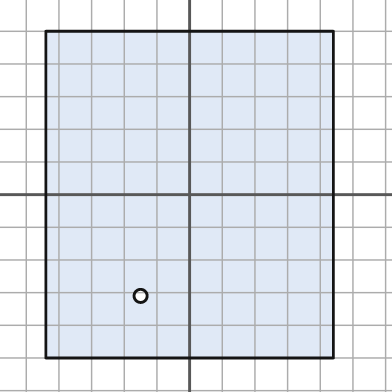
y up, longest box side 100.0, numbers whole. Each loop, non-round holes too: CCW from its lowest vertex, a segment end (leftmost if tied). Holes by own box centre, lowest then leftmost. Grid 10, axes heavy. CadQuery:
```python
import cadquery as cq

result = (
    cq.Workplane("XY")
    .moveTo(-44.0, -50.0)
    .lineTo(44.0, -50.0)
    .lineTo(44.0, 50.0)
    .lineTo(-44.0, 50.0)
    .close()
    .moveTo(-15.0, -31.0)
    .circle(2.0)
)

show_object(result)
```